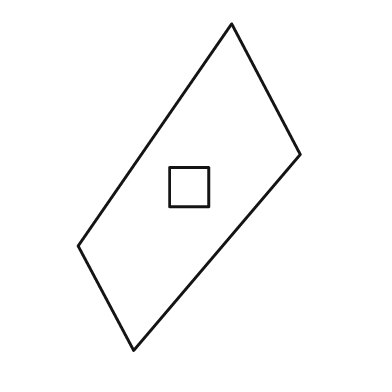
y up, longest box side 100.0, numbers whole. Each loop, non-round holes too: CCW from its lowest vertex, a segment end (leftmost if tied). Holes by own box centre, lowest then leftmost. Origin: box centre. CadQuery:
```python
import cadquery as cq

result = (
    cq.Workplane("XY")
    .moveTo(-17.0, -50.0)
    .lineTo(34.0, 10.0)
    .lineTo(13.0, 50.0)
    .lineTo(-34.0, -18.0)
    .close()
    .moveTo(-6.0, -6.0)
    .lineTo(6.0, -6.0)
    .lineTo(6.0, 6.0)
    .lineTo(-6.0, 6.0)
    .close()
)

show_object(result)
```